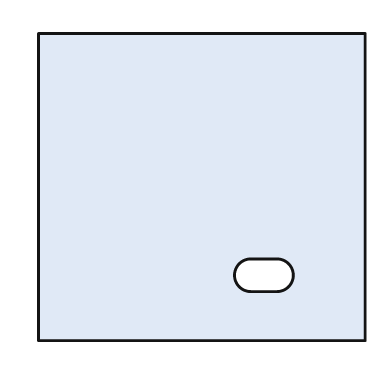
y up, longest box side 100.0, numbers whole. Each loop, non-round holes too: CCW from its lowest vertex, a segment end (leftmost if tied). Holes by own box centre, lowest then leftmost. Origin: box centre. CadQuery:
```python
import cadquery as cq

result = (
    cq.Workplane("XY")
    .moveTo(-50.0, -47.0)
    .lineTo(50.0, -47.0)
    .lineTo(50.0, 47.0)
    .lineTo(-50.0, 47.0)
    .close()
    .moveTo(15.0, -32.0)
    .lineTo(23.0, -32.0)
    .threePointArc((28.0, -27.0), (23.0, -22.0))
    .lineTo(15.0, -22.0)
    .threePointArc((10.0, -27.0), (15.0, -32.0))
    .close()
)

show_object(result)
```